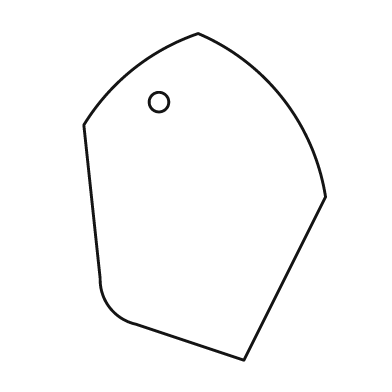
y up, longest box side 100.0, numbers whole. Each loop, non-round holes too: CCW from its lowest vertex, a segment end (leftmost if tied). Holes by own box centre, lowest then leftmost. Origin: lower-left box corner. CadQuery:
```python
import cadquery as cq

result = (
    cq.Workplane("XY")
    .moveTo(49.0, 0.0)
    .lineTo(74.0, 50.0)
    .threePointArc((61.0, 80.0), (35.0, 100.0))
    .threePointArc((15.0, 89.0), (0.0, 72.0))
    .lineTo(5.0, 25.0)
    .threePointArc((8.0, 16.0), (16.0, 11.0))
    .close()
    .moveTo(23.0, 79.0)
    .circle(3.0)
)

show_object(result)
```